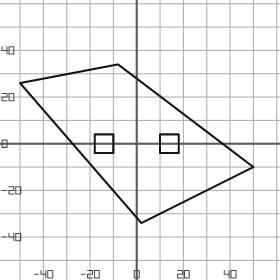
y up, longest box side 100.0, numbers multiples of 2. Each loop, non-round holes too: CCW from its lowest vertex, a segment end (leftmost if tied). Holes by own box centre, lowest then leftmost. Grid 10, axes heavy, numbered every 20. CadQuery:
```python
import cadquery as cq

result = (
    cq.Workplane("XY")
    .moveTo(2.0, -34.0)
    .lineTo(50.0, -10.0)
    .lineTo(-8.0, 34.0)
    .lineTo(-50.0, 26.0)
    .close()
    .moveTo(-18.0, -4.0)
    .lineTo(-10.0, -4.0)
    .lineTo(-10.0, 4.0)
    .lineTo(-18.0, 4.0)
    .close()
    .moveTo(10.0, -4.0)
    .lineTo(18.0, -4.0)
    .lineTo(18.0, 4.0)
    .lineTo(10.0, 4.0)
    .close()
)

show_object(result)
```